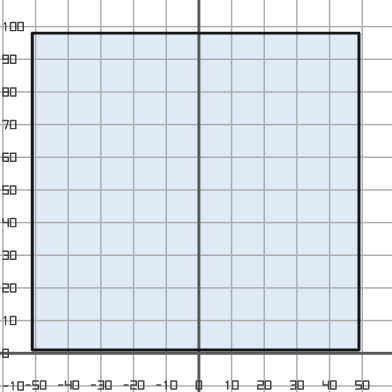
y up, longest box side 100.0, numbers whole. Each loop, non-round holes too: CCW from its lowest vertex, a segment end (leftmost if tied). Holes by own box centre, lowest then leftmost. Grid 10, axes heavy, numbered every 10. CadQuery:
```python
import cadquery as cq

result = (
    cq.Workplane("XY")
    .moveTo(-51.0, 1.0)
    .lineTo(49.0, 1.0)
    .lineTo(49.0, 98.0)
    .lineTo(-51.0, 98.0)
    .close()
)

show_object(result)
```